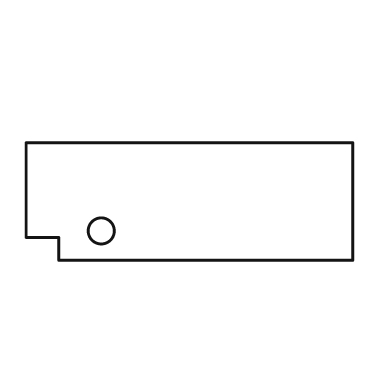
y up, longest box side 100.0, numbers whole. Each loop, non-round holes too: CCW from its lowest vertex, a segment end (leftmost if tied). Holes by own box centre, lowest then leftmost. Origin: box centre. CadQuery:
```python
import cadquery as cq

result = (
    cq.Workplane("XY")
    .moveTo(-40.0, -18.0)
    .lineTo(50.0, -18.0)
    .lineTo(50.0, 18.0)
    .lineTo(-50.0, 18.0)
    .lineTo(-50.0, -11.0)
    .lineTo(-40.0, -11.0)
    .close()
    .moveTo(-27.0, -9.0)
    .circle(4.0)
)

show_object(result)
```